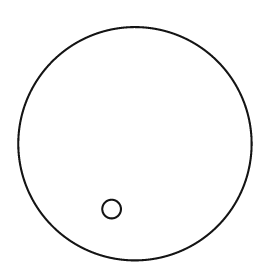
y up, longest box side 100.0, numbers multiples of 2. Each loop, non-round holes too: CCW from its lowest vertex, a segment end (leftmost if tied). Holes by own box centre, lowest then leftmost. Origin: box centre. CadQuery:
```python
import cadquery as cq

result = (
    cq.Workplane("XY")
    .moveTo(0.0, 0.0)
    .circle(50.0)
    .moveTo(-10.0, -28.0)
    .circle(4.0)
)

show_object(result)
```